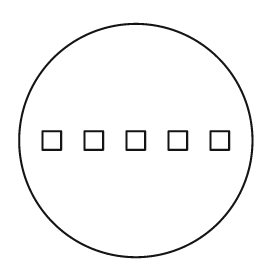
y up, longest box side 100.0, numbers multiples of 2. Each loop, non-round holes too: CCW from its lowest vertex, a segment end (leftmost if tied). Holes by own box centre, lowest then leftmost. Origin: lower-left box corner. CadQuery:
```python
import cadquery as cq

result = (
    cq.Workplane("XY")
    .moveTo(50.0, 50.0)
    .circle(50.0)
    .moveTo(10.0, 46.0)
    .lineTo(18.0, 46.0)
    .lineTo(18.0, 54.0)
    .lineTo(10.0, 54.0)
    .close()
    .moveTo(28.0, 46.0)
    .lineTo(36.0, 46.0)
    .lineTo(36.0, 54.0)
    .lineTo(28.0, 54.0)
    .close()
    .moveTo(46.0, 46.0)
    .lineTo(54.0, 46.0)
    .lineTo(54.0, 54.0)
    .lineTo(46.0, 54.0)
    .close()
    .moveTo(64.0, 46.0)
    .lineTo(72.0, 46.0)
    .lineTo(72.0, 54.0)
    .lineTo(64.0, 54.0)
    .close()
    .moveTo(82.0, 46.0)
    .lineTo(90.0, 46.0)
    .lineTo(90.0, 54.0)
    .lineTo(82.0, 54.0)
    .close()
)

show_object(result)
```